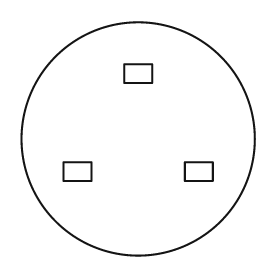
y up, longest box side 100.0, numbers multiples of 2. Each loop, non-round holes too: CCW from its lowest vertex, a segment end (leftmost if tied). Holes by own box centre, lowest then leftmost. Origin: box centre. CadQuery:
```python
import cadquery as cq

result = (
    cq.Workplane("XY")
    .moveTo(0.0, 0.0)
    .circle(50.0)
    .moveTo(-32.0, -18.0)
    .lineTo(-20.0, -18.0)
    .lineTo(-20.0, -10.0)
    .lineTo(-32.0, -10.0)
    .close()
    .moveTo(20.0, -18.0)
    .lineTo(32.0, -18.0)
    .lineTo(32.0, -10.0)
    .lineTo(20.0, -10.0)
    .close()
    .moveTo(-6.0, 24.0)
    .lineTo(6.0, 24.0)
    .lineTo(6.0, 32.0)
    .lineTo(-6.0, 32.0)
    .close()
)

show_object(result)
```